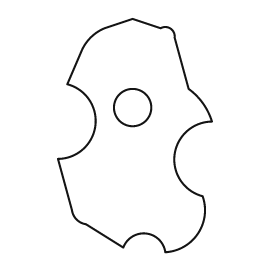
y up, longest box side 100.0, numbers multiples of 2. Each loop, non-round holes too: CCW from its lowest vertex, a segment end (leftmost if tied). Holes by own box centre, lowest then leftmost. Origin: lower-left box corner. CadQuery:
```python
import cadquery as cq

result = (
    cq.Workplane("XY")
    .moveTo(46.0, 0.0)
    .threePointArc((60.0, 8.0), (62.0, 24.0))
    .threePointArc((50.0, 42.0), (66.0, 56.0))
    .threePointArc((62.0, 64.0), (56.0, 70.0))
    .lineTo(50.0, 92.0)
    .threePointArc((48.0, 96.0), (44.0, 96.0))
    .lineTo(32.0, 100.0)
    .lineTo(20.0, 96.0)
    .threePointArc((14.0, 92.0), (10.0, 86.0))
    .lineTo(4.0, 72.0)
    .threePointArc((16.0, 54.0), (0.0, 40.0))
    .lineTo(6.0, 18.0)
    .threePointArc((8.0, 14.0), (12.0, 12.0))
    .lineTo(28.0, 2.0)
    .threePointArc((38.0, 8.0), (46.0, 0.0))
    .close()
    .moveTo(32.0, 62.0)
    .circle(8.0)
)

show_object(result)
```